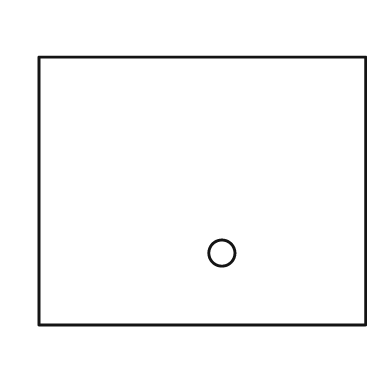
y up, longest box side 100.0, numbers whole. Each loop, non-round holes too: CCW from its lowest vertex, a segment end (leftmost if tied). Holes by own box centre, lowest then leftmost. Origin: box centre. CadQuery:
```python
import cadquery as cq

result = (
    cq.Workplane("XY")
    .moveTo(-50.0, -41.0)
    .lineTo(50.0, -41.0)
    .lineTo(50.0, 41.0)
    .lineTo(-50.0, 41.0)
    .close()
    .moveTo(6.0, -19.0)
    .circle(4.0)
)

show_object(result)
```